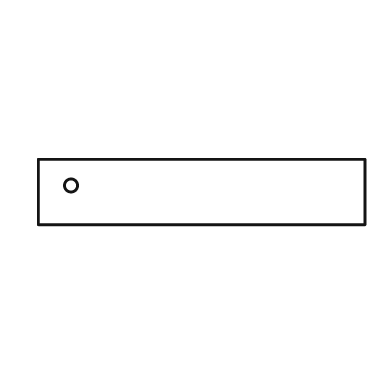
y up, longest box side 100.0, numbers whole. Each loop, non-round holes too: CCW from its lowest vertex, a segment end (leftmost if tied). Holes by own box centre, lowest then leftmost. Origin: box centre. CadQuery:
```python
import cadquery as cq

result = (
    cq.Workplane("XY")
    .moveTo(-50.0, -10.0)
    .lineTo(50.0, -10.0)
    .lineTo(50.0, 10.0)
    .lineTo(-50.0, 10.0)
    .close()
    .moveTo(-40.0, 2.0)
    .circle(2.0)
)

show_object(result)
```